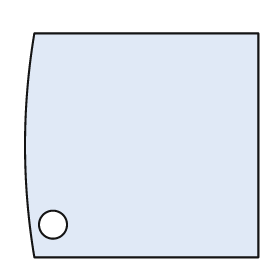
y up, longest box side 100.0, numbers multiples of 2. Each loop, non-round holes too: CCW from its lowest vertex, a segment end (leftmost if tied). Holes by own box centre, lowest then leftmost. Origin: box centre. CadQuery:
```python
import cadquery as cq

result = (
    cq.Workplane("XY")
    .moveTo(-46.0, -48.0)
    .lineTo(50.0, -48.0)
    .lineTo(50.0, 48.0)
    .lineTo(-46.0, 48.0)
    .threePointArc((-50.0, 0.0), (-46.0, -48.0))
    .close()
    .moveTo(-38.0, -34.0)
    .circle(6.0)
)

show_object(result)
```